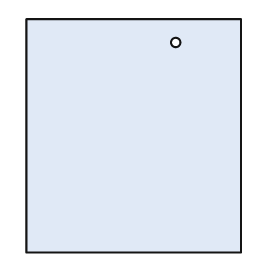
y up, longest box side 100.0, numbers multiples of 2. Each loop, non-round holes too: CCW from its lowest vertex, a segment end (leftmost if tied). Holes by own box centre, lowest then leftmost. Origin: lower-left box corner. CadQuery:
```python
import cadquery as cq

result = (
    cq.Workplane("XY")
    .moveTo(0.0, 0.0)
    .lineTo(92.0, 0.0)
    .lineTo(92.0, 100.0)
    .lineTo(0.0, 100.0)
    .close()
    .moveTo(64.0, 90.0)
    .circle(2.0)
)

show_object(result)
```